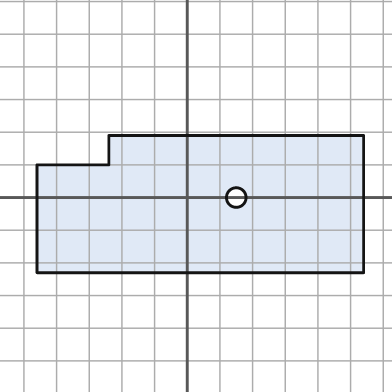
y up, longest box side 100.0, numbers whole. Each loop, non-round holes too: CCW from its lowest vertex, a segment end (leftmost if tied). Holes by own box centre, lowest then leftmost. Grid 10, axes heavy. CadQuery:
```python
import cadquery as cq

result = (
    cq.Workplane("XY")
    .moveTo(-46.0, -23.0)
    .lineTo(54.0, -23.0)
    .lineTo(54.0, 19.0)
    .lineTo(-24.0, 19.0)
    .lineTo(-24.0, 10.0)
    .lineTo(-46.0, 10.0)
    .close()
    .moveTo(15.0, 0.0)
    .circle(3.0)
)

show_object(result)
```